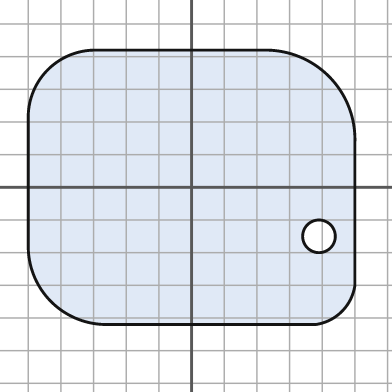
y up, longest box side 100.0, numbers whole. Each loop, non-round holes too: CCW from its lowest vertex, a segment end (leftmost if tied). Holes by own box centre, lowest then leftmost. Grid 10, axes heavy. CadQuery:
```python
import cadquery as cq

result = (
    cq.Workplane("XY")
    .moveTo(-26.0, -42.0)
    .lineTo(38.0, -42.0)
    .threePointArc((46.0, -38.0), (50.0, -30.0))
    .lineTo(50.0, 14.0)
    .threePointArc((42.0, 34.0), (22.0, 42.0))
    .lineTo(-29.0, 42.0)
    .threePointArc((-44.0, 36.0), (-50.0, 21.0))
    .lineTo(-50.0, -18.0)
    .threePointArc((-43.0, -35.0), (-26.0, -42.0))
    .close()
    .moveTo(39.0, -15.0)
    .circle(5.0)
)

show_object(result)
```